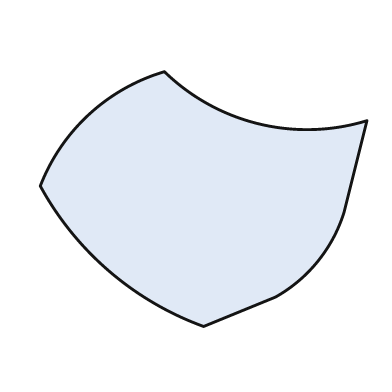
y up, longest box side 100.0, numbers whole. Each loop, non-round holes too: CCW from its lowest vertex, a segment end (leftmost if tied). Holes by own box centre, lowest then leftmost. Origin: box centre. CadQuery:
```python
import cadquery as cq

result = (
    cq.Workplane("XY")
    .moveTo(0.0, -39.0)
    .lineTo(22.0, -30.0)
    .threePointArc((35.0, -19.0), (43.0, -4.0))
    .lineTo(50.0, 24.0)
    .threePointArc((17.0, 23.0), (-12.0, 39.0))
    .threePointArc((-35.0, 26.0), (-50.0, 4.0))
    .threePointArc((-29.0, -22.0), (0.0, -39.0))
    .close()
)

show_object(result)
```